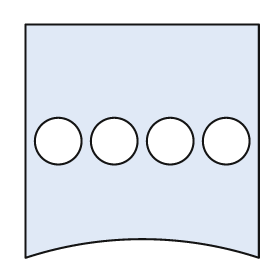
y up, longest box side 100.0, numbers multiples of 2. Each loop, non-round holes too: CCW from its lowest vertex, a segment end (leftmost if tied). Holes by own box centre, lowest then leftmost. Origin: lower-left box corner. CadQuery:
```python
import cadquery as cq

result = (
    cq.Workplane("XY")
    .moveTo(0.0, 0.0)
    .threePointArc((50.0, 8.0), (100.0, 0.0))
    .lineTo(100.0, 100.0)
    .lineTo(0.0, 100.0)
    .close()
    .moveTo(14.0, 50.0)
    .circle(10.0)
    .moveTo(38.0, 50.0)
    .circle(10.0)
    .moveTo(62.0, 50.0)
    .circle(10.0)
    .moveTo(86.0, 50.0)
    .circle(10.0)
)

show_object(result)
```